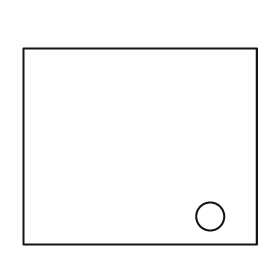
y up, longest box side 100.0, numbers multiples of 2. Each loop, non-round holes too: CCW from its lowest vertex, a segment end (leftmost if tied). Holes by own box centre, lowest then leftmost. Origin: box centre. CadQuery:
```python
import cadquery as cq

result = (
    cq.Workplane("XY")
    .moveTo(-50.0, -42.0)
    .lineTo(50.0, -42.0)
    .lineTo(50.0, 42.0)
    .lineTo(-50.0, 42.0)
    .close()
    .moveTo(30.0, -30.0)
    .circle(6.0)
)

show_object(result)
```